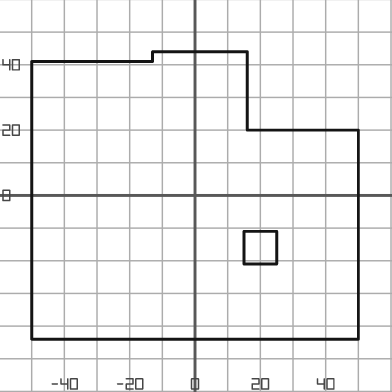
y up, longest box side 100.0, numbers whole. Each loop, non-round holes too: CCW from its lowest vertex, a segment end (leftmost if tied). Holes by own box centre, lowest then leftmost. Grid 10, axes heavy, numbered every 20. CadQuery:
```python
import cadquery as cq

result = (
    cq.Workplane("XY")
    .moveTo(-50.0, -44.0)
    .lineTo(50.0, -44.0)
    .lineTo(50.0, 20.0)
    .lineTo(16.0, 20.0)
    .lineTo(16.0, 44.0)
    .lineTo(-13.0, 44.0)
    .lineTo(-13.0, 41.0)
    .lineTo(-50.0, 41.0)
    .close()
    .moveTo(15.0, -21.0)
    .lineTo(25.0, -21.0)
    .lineTo(25.0, -11.0)
    .lineTo(15.0, -11.0)
    .close()
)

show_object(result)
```